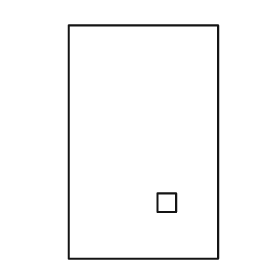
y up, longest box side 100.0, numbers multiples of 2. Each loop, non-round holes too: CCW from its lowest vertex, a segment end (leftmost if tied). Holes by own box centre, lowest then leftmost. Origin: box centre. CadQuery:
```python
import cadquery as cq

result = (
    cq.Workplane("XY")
    .moveTo(-32.0, -50.0)
    .lineTo(32.0, -50.0)
    .lineTo(32.0, 50.0)
    .lineTo(-32.0, 50.0)
    .close()
    .moveTo(6.0, -30.0)
    .lineTo(14.0, -30.0)
    .lineTo(14.0, -22.0)
    .lineTo(6.0, -22.0)
    .close()
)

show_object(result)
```